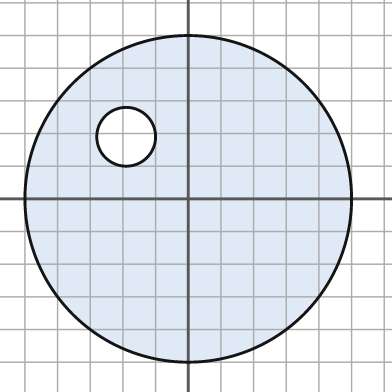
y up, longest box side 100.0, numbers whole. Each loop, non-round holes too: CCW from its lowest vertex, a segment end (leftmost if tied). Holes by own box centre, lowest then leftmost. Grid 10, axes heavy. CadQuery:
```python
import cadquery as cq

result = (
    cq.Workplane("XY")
    .moveTo(0.0, 0.0)
    .circle(50.0)
    .moveTo(-19.0, 19.0)
    .circle(9.0)
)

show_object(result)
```